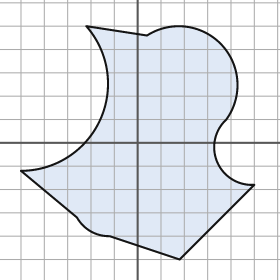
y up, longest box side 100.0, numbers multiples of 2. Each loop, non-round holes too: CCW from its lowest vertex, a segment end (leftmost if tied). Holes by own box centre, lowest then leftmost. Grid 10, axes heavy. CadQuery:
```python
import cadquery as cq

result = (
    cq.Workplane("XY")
    .moveTo(18.0, -50.0)
    .lineTo(50.0, -18.0)
    .threePointArc((34.0, -8.0), (38.0, 10.0))
    .threePointArc((36.0, 42.0), (4.0, 46.0))
    .lineTo(-22.0, 50.0)
    .threePointArc((-16.0, 10.0), (-50.0, -12.0))
    .lineTo(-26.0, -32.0)
    .threePointArc((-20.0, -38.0), (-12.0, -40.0))
    .close()
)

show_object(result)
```